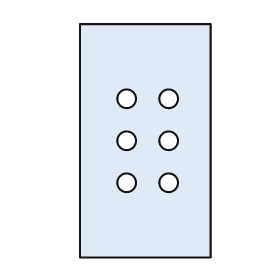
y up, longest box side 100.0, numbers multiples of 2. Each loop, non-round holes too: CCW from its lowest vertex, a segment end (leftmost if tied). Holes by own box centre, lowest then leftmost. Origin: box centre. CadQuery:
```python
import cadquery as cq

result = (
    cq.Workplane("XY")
    .moveTo(-28.0, -50.0)
    .lineTo(28.0, -50.0)
    .lineTo(28.0, 50.0)
    .lineTo(-28.0, 50.0)
    .close()
    .moveTo(-8.0, -18.0)
    .circle(4.0)
    .moveTo(10.0, -18.0)
    .circle(4.0)
    .moveTo(-8.0, 0.0)
    .circle(4.0)
    .moveTo(10.0, 0.0)
    .circle(4.0)
    .moveTo(-8.0, 18.0)
    .circle(4.0)
    .moveTo(10.0, 18.0)
    .circle(4.0)
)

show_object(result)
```